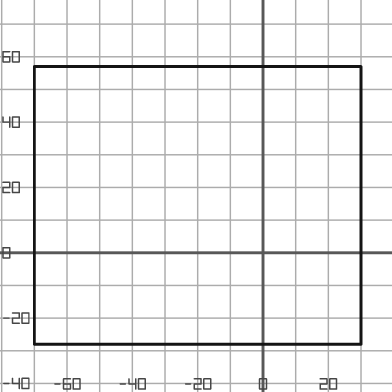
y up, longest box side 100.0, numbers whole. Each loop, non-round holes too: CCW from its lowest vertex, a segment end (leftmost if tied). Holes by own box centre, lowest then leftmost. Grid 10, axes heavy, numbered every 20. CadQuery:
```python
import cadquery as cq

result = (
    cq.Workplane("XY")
    .moveTo(-70.0, -28.0)
    .lineTo(30.0, -28.0)
    .lineTo(30.0, 57.0)
    .lineTo(-70.0, 57.0)
    .close()
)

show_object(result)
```